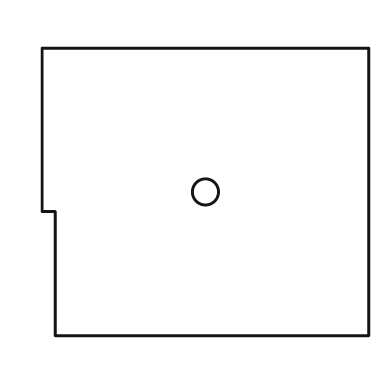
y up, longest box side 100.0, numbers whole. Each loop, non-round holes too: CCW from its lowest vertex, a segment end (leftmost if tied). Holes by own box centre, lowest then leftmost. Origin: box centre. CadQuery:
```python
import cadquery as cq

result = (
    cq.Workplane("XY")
    .moveTo(-46.0, -44.0)
    .lineTo(50.0, -44.0)
    .lineTo(50.0, 44.0)
    .lineTo(-50.0, 44.0)
    .lineTo(-50.0, -6.0)
    .lineTo(-46.0, -6.0)
    .close()
    .moveTo(0.0, 0.0)
    .circle(4.0)
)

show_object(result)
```